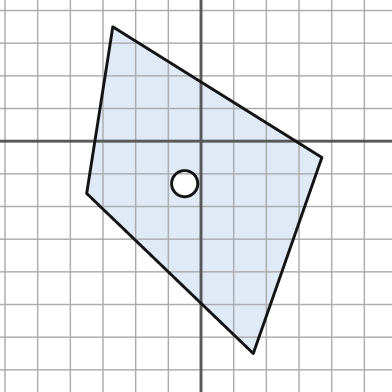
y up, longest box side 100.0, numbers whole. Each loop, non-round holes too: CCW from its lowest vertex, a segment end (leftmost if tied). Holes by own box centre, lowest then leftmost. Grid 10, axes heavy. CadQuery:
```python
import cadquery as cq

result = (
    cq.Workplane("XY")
    .moveTo(16.0, -65.0)
    .lineTo(37.0, -5.0)
    .lineTo(-27.0, 35.0)
    .lineTo(-35.0, -16.0)
    .close()
    .moveTo(-5.0, -13.0)
    .circle(4.0)
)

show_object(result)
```